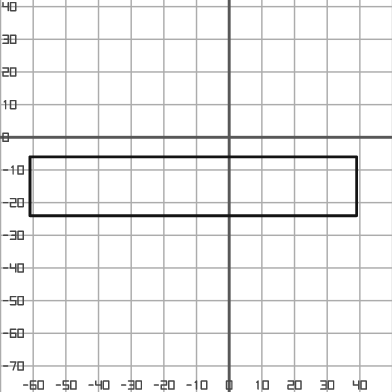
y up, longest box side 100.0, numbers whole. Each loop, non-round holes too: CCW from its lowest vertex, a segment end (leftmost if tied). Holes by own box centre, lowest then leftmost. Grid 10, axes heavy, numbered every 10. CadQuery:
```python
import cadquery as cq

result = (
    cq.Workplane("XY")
    .moveTo(-61.0, -24.0)
    .lineTo(39.0, -24.0)
    .lineTo(39.0, -6.0)
    .lineTo(-61.0, -6.0)
    .close()
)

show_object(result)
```